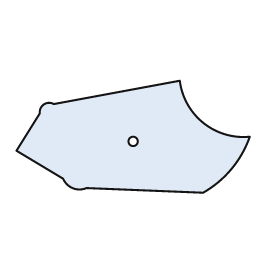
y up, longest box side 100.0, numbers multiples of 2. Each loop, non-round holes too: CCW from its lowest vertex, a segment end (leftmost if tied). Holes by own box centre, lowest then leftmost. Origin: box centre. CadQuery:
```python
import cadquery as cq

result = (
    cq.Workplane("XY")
    .moveTo(30.0, -24.0)
    .threePointArc((42.0, -14.0), (50.0, 0.0))
    .threePointArc((30.0, 6.0), (20.0, 24.0))
    .lineTo(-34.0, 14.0)
    .threePointArc((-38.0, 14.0), (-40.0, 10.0))
    .lineTo(-50.0, -6.0)
    .lineTo(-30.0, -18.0)
    .threePointArc((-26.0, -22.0), (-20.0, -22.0))
    .close()
    .moveTo(0.0, -2.0)
    .circle(2.0)
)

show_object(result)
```